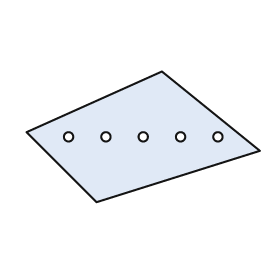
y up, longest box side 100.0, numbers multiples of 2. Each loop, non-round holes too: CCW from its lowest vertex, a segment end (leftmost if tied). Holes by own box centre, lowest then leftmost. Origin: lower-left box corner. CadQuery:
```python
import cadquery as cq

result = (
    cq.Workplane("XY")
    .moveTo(30.0, 0.0)
    .lineTo(100.0, 22.0)
    .lineTo(58.0, 56.0)
    .lineTo(0.0, 30.0)
    .close()
    .moveTo(18.0, 28.0)
    .circle(2.0)
    .moveTo(34.0, 28.0)
    .circle(2.0)
    .moveTo(50.0, 28.0)
    .circle(2.0)
    .moveTo(66.0, 28.0)
    .circle(2.0)
    .moveTo(82.0, 28.0)
    .circle(2.0)
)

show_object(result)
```